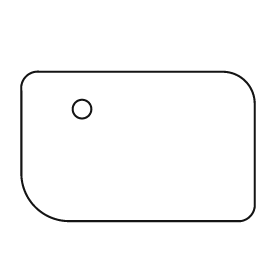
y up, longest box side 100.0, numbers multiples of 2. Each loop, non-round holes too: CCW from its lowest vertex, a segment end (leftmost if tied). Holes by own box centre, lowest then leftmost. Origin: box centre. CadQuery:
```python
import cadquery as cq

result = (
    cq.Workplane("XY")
    .moveTo(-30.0, -32.0)
    .lineTo(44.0, -32.0)
    .threePointArc((48.0, -30.0), (50.0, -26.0))
    .lineTo(50.0, 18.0)
    .threePointArc((46.0, 28.0), (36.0, 32.0))
    .lineTo(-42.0, 32.0)
    .threePointArc((-48.0, 30.0), (-50.0, 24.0))
    .lineTo(-50.0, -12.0)
    .threePointArc((-44.0, -26.0), (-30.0, -32.0))
    .close()
    .moveTo(-24.0, 16.0)
    .circle(4.0)
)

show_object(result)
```